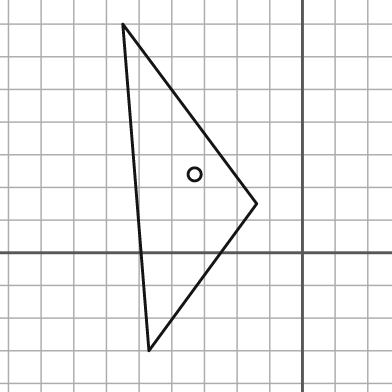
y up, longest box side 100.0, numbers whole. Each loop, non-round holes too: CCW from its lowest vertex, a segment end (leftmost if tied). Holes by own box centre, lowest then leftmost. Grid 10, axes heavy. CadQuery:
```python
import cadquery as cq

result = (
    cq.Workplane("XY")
    .moveTo(-47.0, -30.0)
    .lineTo(-14.0, 15.0)
    .lineTo(-55.0, 70.0)
    .close()
    .moveTo(-33.0, 24.0)
    .circle(2.0)
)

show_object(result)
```